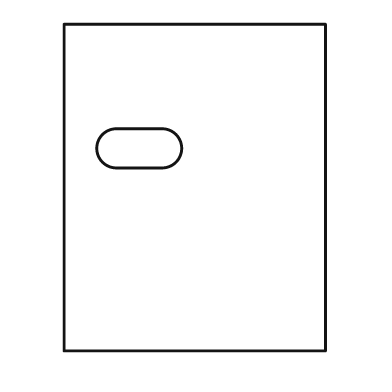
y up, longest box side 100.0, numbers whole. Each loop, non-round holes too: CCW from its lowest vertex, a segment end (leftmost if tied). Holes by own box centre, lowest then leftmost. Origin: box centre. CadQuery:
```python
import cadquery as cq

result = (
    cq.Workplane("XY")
    .moveTo(-40.0, -50.0)
    .lineTo(40.0, -50.0)
    .lineTo(40.0, 50.0)
    .lineTo(-40.0, 50.0)
    .close()
    .moveTo(-24.0, 6.0)
    .lineTo(-10.0, 6.0)
    .threePointArc((-4.0, 12.0), (-10.0, 18.0))
    .lineTo(-24.0, 18.0)
    .threePointArc((-30.0, 12.0), (-24.0, 6.0))
    .close()
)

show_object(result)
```